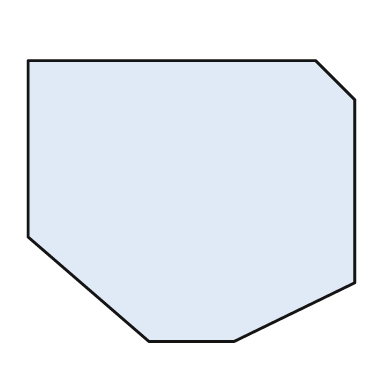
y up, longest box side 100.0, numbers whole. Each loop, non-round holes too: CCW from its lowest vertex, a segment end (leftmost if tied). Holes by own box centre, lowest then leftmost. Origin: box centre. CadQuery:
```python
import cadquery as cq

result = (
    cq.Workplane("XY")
    .moveTo(-13.0, -43.0)
    .lineTo(13.0, -43.0)
    .lineTo(50.0, -25.0)
    .lineTo(50.0, 31.0)
    .lineTo(38.0, 43.0)
    .lineTo(-50.0, 43.0)
    .lineTo(-50.0, -11.0)
    .close()
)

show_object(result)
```